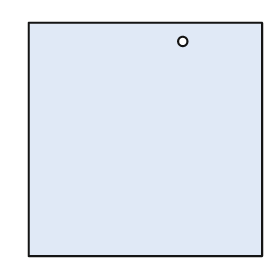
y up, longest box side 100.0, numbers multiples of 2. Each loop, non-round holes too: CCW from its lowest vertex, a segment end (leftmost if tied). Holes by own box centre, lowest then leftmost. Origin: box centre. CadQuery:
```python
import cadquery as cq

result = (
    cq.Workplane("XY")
    .moveTo(-50.0, -50.0)
    .lineTo(50.0, -50.0)
    .lineTo(50.0, 50.0)
    .lineTo(-50.0, 50.0)
    .close()
    .moveTo(16.0, 42.0)
    .circle(2.0)
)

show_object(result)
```